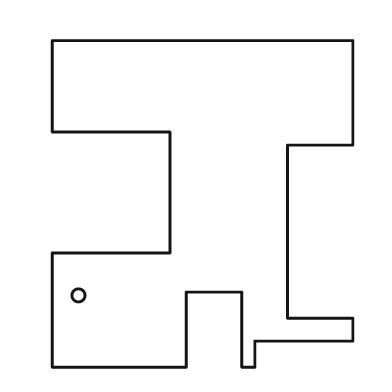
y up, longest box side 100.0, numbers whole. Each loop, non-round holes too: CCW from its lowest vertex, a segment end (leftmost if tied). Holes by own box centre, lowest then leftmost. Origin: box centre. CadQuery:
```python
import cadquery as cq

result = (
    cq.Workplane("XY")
    .moveTo(-46.0, -50.0)
    .lineTo(-5.0, -50.0)
    .lineTo(-5.0, -27.0)
    .lineTo(12.0, -27.0)
    .lineTo(12.0, -50.0)
    .lineTo(16.0, -50.0)
    .lineTo(16.0, -42.0)
    .lineTo(46.0, -42.0)
    .lineTo(46.0, -35.0)
    .lineTo(26.0, -35.0)
    .lineTo(26.0, 18.0)
    .lineTo(46.0, 18.0)
    .lineTo(46.0, 50.0)
    .lineTo(-46.0, 50.0)
    .lineTo(-46.0, 22.0)
    .lineTo(-10.0, 22.0)
    .lineTo(-10.0, -15.0)
    .lineTo(-46.0, -15.0)
    .close()
    .moveTo(-38.0, -28.0)
    .circle(2.0)
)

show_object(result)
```